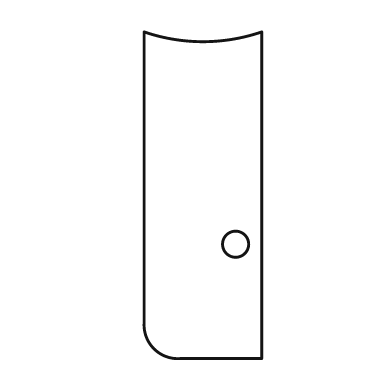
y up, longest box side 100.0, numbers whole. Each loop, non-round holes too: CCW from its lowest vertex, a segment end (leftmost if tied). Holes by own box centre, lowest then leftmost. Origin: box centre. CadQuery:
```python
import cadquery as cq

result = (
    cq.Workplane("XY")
    .moveTo(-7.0, -50.0)
    .lineTo(18.0, -50.0)
    .lineTo(18.0, 50.0)
    .threePointArc((0.0, 47.0), (-18.0, 50.0))
    .lineTo(-18.0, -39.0)
    .threePointArc((-15.0, -47.0), (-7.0, -50.0))
    .close()
    .moveTo(10.0, -15.0)
    .circle(4.0)
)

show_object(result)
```